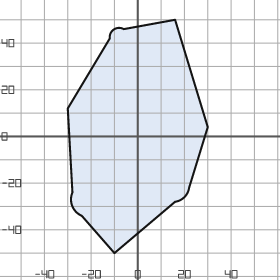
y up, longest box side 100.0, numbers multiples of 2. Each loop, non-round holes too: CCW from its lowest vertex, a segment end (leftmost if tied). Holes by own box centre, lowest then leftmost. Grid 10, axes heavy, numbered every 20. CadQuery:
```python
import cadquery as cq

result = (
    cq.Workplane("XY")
    .moveTo(-10.0, -50.0)
    .lineTo(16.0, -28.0)
    .threePointArc((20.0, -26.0), (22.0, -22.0))
    .lineTo(30.0, 4.0)
    .lineTo(16.0, 50.0)
    .lineTo(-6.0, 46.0)
    .threePointArc((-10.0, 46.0), (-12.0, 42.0))
    .lineTo(-30.0, 12.0)
    .lineTo(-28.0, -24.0)
    .threePointArc((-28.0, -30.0), (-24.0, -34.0))
    .close()
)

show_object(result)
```